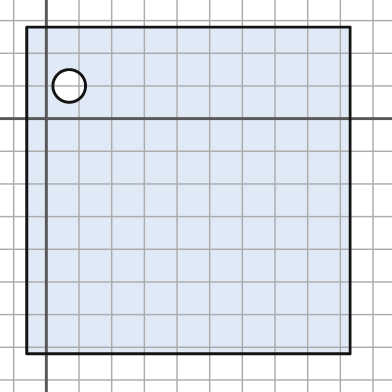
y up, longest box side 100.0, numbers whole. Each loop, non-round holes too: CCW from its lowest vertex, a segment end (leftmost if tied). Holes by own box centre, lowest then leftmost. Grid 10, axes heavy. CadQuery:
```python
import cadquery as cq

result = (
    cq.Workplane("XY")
    .moveTo(-6.0, -72.0)
    .lineTo(93.0, -72.0)
    .lineTo(93.0, 28.0)
    .lineTo(-6.0, 28.0)
    .close()
    .moveTo(7.0, 10.0)
    .circle(5.0)
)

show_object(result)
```